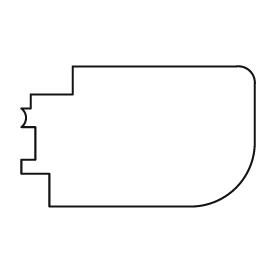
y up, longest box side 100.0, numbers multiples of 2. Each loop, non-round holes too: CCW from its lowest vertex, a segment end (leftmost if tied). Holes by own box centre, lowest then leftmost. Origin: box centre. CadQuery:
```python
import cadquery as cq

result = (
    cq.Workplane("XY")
    .moveTo(-38.0, -30.0)
    .lineTo(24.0, -30.0)
    .threePointArc((42.0, -22.0), (50.0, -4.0))
    .lineTo(50.0, 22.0)
    .threePointArc((48.0, 28.0), (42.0, 30.0))
    .lineTo(-28.0, 30.0)
    .lineTo(-28.0, 18.0)
    .lineTo(-46.0, 18.0)
    .lineTo(-46.0, 12.0)
    .lineTo(-50.0, 12.0)
    .threePointArc((-48.0, 8.0), (-50.0, 4.0))
    .lineTo(-44.0, 4.0)
    .lineTo(-44.0, -10.0)
    .lineTo(-50.0, -10.0)
    .lineTo(-50.0, -16.0)
    .lineTo(-38.0, -16.0)
    .close()
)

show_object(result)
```